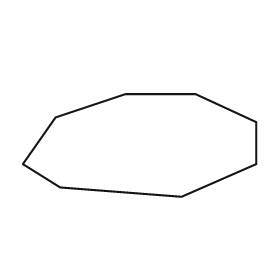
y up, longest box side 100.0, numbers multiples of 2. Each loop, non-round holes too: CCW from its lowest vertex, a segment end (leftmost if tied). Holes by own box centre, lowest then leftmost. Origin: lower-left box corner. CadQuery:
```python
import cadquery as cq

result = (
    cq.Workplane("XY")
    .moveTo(68.0, 0.0)
    .lineTo(100.0, 14.0)
    .lineTo(100.0, 32.0)
    .lineTo(74.0, 44.0)
    .lineTo(44.0, 44.0)
    .lineTo(14.0, 34.0)
    .lineTo(0.0, 14.0)
    .lineTo(16.0, 4.0)
    .close()
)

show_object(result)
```